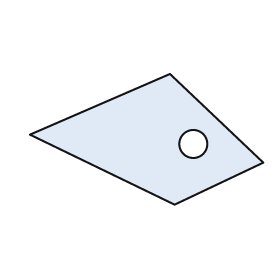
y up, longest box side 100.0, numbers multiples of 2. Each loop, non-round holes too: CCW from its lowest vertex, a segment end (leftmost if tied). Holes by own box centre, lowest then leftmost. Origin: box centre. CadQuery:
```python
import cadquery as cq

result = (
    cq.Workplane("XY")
    .moveTo(12.0, -28.0)
    .lineTo(50.0, -10.0)
    .lineTo(10.0, 28.0)
    .lineTo(-50.0, 2.0)
    .close()
    .moveTo(20.0, -2.0)
    .circle(6.0)
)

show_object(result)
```